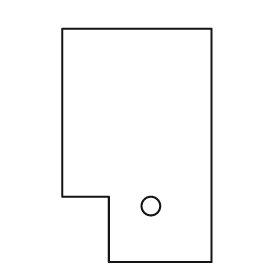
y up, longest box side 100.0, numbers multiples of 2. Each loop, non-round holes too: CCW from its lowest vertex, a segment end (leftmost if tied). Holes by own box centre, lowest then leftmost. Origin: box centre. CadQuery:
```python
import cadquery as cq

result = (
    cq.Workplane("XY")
    .moveTo(-12.0, -50.0)
    .lineTo(32.0, -50.0)
    .lineTo(32.0, 50.0)
    .lineTo(-32.0, 50.0)
    .lineTo(-32.0, -22.0)
    .lineTo(-12.0, -22.0)
    .close()
    .moveTo(6.0, -26.0)
    .circle(4.0)
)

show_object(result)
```